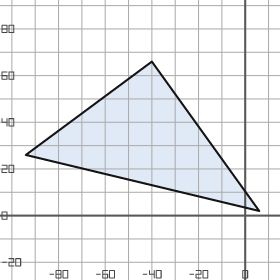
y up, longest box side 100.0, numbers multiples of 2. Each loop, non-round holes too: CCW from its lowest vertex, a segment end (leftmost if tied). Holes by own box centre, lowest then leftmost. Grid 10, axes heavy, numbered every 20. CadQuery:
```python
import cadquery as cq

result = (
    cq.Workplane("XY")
    .moveTo(6.0, 2.0)
    .lineTo(-40.0, 66.0)
    .lineTo(-94.0, 26.0)
    .close()
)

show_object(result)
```